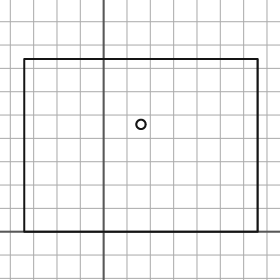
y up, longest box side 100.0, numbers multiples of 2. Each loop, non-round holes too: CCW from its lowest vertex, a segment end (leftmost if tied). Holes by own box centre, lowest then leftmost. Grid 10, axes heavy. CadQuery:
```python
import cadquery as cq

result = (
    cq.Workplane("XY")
    .moveTo(-34.0, 0.0)
    .lineTo(66.0, 0.0)
    .lineTo(66.0, 74.0)
    .lineTo(-34.0, 74.0)
    .close()
    .moveTo(16.0, 46.0)
    .circle(2.0)
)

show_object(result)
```